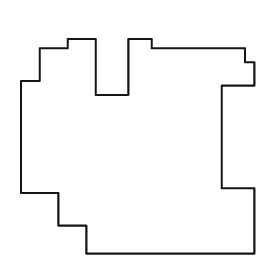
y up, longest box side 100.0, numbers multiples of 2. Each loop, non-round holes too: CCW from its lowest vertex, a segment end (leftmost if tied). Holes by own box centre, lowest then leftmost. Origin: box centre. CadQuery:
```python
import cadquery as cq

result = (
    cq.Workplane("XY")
    .moveTo(-22.0, -46.0)
    .lineTo(50.0, -46.0)
    .lineTo(50.0, -18.0)
    .lineTo(36.0, -18.0)
    .lineTo(36.0, 26.0)
    .lineTo(50.0, 26.0)
    .lineTo(50.0, 36.0)
    .lineTo(46.0, 36.0)
    .lineTo(46.0, 42.0)
    .lineTo(6.0, 42.0)
    .lineTo(6.0, 46.0)
    .lineTo(-4.0, 46.0)
    .lineTo(-4.0, 22.0)
    .lineTo(-18.0, 22.0)
    .lineTo(-18.0, 46.0)
    .lineTo(-30.0, 46.0)
    .lineTo(-30.0, 42.0)
    .lineTo(-42.0, 42.0)
    .lineTo(-42.0, 28.0)
    .lineTo(-50.0, 28.0)
    .lineTo(-50.0, -20.0)
    .lineTo(-34.0, -20.0)
    .lineTo(-34.0, -34.0)
    .lineTo(-22.0, -34.0)
    .close()
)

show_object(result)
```